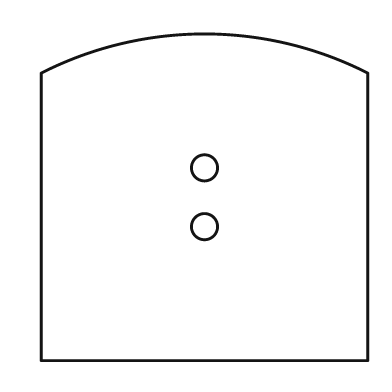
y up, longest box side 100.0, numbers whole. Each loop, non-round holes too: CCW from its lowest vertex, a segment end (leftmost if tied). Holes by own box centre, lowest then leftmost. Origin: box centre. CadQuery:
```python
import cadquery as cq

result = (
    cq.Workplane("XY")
    .moveTo(-50.0, -50.0)
    .lineTo(50.0, -50.0)
    .lineTo(50.0, 38.0)
    .threePointArc((0.0, 50.0), (-50.0, 38.0))
    .close()
    .moveTo(0.0, -9.0)
    .circle(4.0)
    .moveTo(0.0, 9.0)
    .circle(4.0)
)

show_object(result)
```